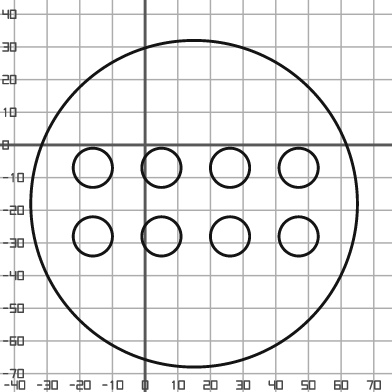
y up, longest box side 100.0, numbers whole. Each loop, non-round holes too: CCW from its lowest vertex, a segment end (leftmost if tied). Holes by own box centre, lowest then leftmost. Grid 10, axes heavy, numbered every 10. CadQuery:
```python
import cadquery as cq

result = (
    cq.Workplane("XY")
    .moveTo(15.0, -18.0)
    .circle(50.0)
    .moveTo(-16.0, -28.0)
    .circle(6.0)
    .moveTo(5.0, -28.0)
    .circle(6.0)
    .moveTo(26.0, -28.0)
    .circle(6.0)
    .moveTo(47.0, -28.0)
    .circle(6.0)
    .moveTo(-16.0, -7.0)
    .circle(6.0)
    .moveTo(5.0, -7.0)
    .circle(6.0)
    .moveTo(26.0, -7.0)
    .circle(6.0)
    .moveTo(47.0, -7.0)
    .circle(6.0)
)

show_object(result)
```